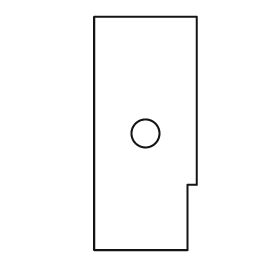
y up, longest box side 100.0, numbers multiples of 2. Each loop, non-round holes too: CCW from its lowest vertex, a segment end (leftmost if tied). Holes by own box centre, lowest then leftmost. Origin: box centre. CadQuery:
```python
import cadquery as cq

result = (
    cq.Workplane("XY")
    .moveTo(-22.0, -50.0)
    .lineTo(18.0, -50.0)
    .lineTo(18.0, -22.0)
    .lineTo(22.0, -22.0)
    .lineTo(22.0, 50.0)
    .lineTo(-22.0, 50.0)
    .close()
    .moveTo(0.0, 0.0)
    .circle(6.0)
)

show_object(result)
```